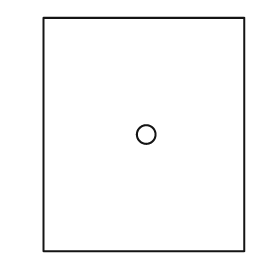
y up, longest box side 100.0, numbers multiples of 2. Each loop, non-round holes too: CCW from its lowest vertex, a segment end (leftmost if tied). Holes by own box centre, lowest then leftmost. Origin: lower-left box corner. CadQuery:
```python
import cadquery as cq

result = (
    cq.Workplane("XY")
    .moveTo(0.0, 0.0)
    .lineTo(86.0, 0.0)
    .lineTo(86.0, 100.0)
    .lineTo(0.0, 100.0)
    .close()
    .moveTo(44.0, 50.0)
    .circle(4.0)
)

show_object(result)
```